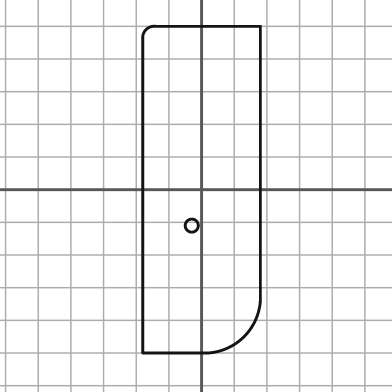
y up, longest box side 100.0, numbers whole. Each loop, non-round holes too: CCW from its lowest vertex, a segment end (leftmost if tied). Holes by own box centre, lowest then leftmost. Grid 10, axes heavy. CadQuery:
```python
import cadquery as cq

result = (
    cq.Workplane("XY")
    .moveTo(-18.0, -50.0)
    .lineTo(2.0, -50.0)
    .threePointArc((13.0, -45.0), (18.0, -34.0))
    .lineTo(18.0, 50.0)
    .lineTo(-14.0, 50.0)
    .threePointArc((-17.0, 49.0), (-18.0, 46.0))
    .close()
    .moveTo(-3.0, -11.0)
    .circle(2.0)
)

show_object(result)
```